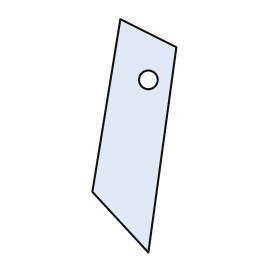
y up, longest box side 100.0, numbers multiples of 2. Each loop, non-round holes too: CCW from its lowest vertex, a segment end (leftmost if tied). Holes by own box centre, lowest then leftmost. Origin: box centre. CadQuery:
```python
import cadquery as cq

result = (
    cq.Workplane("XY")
    .moveTo(6.0, -50.0)
    .lineTo(18.0, 38.0)
    .lineTo(-6.0, 50.0)
    .lineTo(-18.0, -24.0)
    .close()
    .moveTo(6.0, 24.0)
    .circle(4.0)
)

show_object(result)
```